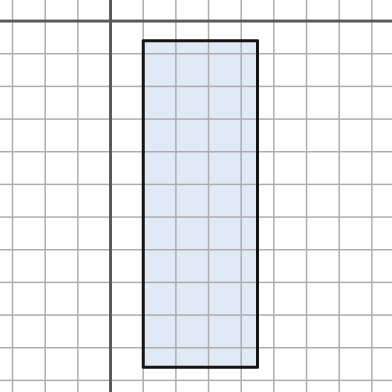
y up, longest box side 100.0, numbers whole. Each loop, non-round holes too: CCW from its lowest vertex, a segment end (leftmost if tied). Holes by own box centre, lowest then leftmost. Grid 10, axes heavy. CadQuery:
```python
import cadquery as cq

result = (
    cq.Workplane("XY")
    .moveTo(10.0, -106.0)
    .lineTo(45.0, -106.0)
    .lineTo(45.0, -6.0)
    .lineTo(10.0, -6.0)
    .close()
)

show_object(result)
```